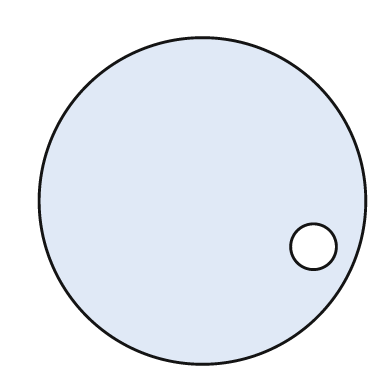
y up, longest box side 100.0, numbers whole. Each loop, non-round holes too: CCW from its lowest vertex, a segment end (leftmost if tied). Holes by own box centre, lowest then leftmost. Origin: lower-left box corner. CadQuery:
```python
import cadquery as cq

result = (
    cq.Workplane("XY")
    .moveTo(50.0, 50.0)
    .circle(50.0)
    .moveTo(84.0, 36.0)
    .circle(7.0)
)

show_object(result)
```